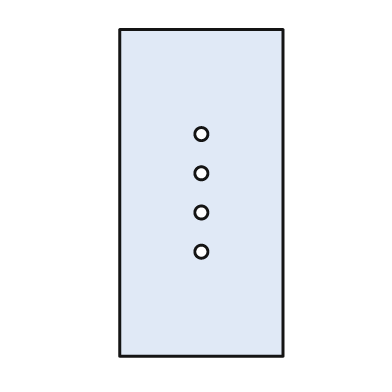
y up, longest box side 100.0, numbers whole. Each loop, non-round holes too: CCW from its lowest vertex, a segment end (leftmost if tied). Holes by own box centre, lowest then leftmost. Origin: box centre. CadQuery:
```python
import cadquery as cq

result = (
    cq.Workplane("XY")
    .moveTo(-25.0, -50.0)
    .lineTo(25.0, -50.0)
    .lineTo(25.0, 50.0)
    .lineTo(-25.0, 50.0)
    .close()
    .moveTo(0.0, -18.0)
    .circle(2.0)
    .moveTo(0.0, -6.0)
    .circle(2.0)
    .moveTo(0.0, 6.0)
    .circle(2.0)
    .moveTo(0.0, 18.0)
    .circle(2.0)
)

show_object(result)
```